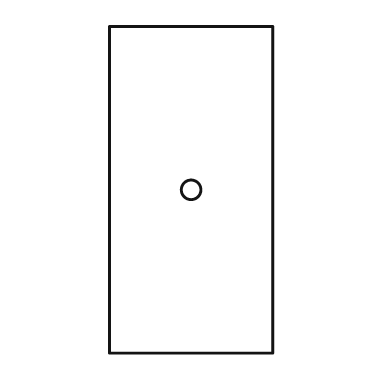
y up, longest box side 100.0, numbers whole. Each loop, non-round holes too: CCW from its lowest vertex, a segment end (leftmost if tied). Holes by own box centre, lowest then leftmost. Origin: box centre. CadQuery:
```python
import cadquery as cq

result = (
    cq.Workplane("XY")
    .moveTo(-25.0, -50.0)
    .lineTo(25.0, -50.0)
    .lineTo(25.0, 50.0)
    .lineTo(-25.0, 50.0)
    .close()
    .moveTo(0.0, 0.0)
    .circle(3.0)
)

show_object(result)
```